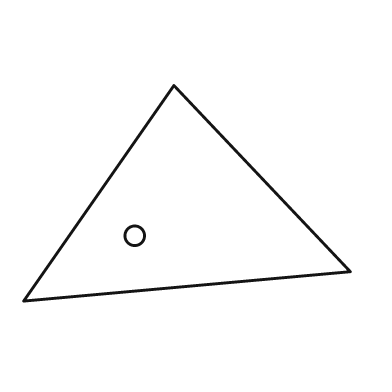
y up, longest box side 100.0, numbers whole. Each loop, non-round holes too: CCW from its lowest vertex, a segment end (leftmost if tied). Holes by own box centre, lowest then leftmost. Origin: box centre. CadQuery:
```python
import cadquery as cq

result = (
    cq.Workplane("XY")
    .moveTo(-50.0, -33.0)
    .lineTo(50.0, -24.0)
    .lineTo(-4.0, 33.0)
    .close()
    .moveTo(-16.0, -13.0)
    .circle(3.0)
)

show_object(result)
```